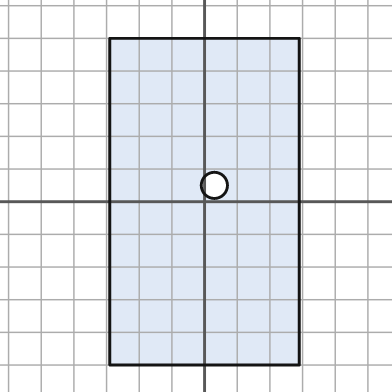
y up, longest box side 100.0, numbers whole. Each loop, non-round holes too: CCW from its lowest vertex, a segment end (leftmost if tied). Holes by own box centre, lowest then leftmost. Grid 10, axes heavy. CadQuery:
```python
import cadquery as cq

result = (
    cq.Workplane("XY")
    .moveTo(-29.0, -50.0)
    .lineTo(29.0, -50.0)
    .lineTo(29.0, 50.0)
    .lineTo(-29.0, 50.0)
    .close()
    .moveTo(3.0, 5.0)
    .circle(4.0)
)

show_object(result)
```